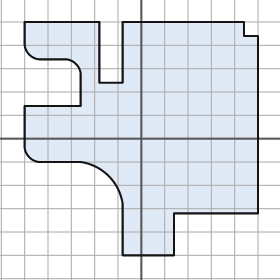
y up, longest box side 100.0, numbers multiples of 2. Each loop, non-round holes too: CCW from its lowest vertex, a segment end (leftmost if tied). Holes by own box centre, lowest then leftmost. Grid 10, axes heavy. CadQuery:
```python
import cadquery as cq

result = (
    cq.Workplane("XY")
    .moveTo(-8.0, -50.0)
    .lineTo(14.0, -50.0)
    .lineTo(14.0, -32.0)
    .lineTo(50.0, -32.0)
    .lineTo(50.0, 44.0)
    .lineTo(44.0, 44.0)
    .lineTo(44.0, 50.0)
    .lineTo(-8.0, 50.0)
    .lineTo(-8.0, 24.0)
    .lineTo(-18.0, 24.0)
    .lineTo(-18.0, 50.0)
    .lineTo(-50.0, 50.0)
    .lineTo(-50.0, 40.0)
    .threePointArc((-48.0, 36.0), (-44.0, 34.0))
    .lineTo(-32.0, 34.0)
    .threePointArc((-28.0, 32.0), (-26.0, 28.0))
    .lineTo(-26.0, 14.0)
    .lineTo(-50.0, 14.0)
    .lineTo(-50.0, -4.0)
    .threePointArc((-48.0, -8.0), (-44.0, -10.0))
    .lineTo(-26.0, -10.0)
    .threePointArc((-14.0, -16.0), (-8.0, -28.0))
    .close()
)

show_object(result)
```